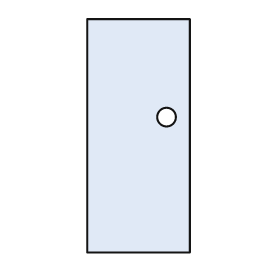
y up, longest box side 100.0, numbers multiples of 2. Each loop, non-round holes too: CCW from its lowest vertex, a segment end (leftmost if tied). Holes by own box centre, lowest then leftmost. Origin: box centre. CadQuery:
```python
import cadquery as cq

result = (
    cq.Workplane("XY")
    .moveTo(-22.0, -50.0)
    .lineTo(22.0, -50.0)
    .lineTo(22.0, 50.0)
    .lineTo(-22.0, 50.0)
    .close()
    .moveTo(12.0, 8.0)
    .circle(4.0)
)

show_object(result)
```